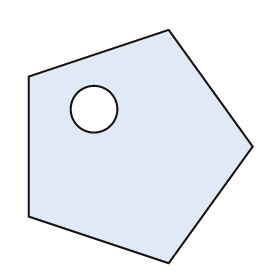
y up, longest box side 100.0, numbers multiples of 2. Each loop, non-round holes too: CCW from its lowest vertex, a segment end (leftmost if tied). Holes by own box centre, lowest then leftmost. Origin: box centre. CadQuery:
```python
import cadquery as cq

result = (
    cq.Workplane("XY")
    .moveTo(12.0, -50.0)
    .lineTo(48.0, 0.0)
    .lineTo(12.0, 50.0)
    .lineTo(-48.0, 30.0)
    .lineTo(-48.0, -30.0)
    .close()
    .moveTo(-20.0, 16.0)
    .circle(10.0)
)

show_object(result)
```